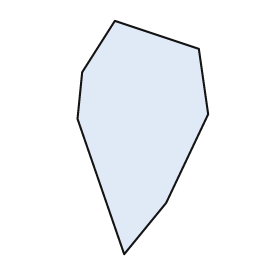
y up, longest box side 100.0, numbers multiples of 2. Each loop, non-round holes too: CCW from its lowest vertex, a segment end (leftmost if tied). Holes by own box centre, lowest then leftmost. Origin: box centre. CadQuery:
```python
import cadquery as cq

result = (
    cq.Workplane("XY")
    .moveTo(-8.0, -50.0)
    .lineTo(10.0, -28.0)
    .lineTo(28.0, 10.0)
    .lineTo(24.0, 38.0)
    .lineTo(-12.0, 50.0)
    .lineTo(-26.0, 28.0)
    .lineTo(-28.0, 8.0)
    .close()
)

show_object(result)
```